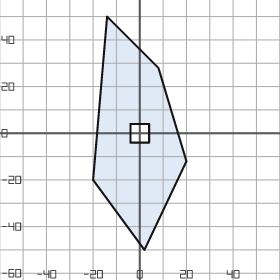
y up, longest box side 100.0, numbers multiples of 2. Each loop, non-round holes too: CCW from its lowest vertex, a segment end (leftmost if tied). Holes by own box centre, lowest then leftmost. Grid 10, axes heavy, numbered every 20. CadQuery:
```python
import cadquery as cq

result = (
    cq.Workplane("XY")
    .moveTo(2.0, -50.0)
    .lineTo(20.0, -12.0)
    .lineTo(8.0, 28.0)
    .lineTo(-14.0, 50.0)
    .lineTo(-20.0, -20.0)
    .close()
    .moveTo(-4.0, -4.0)
    .lineTo(4.0, -4.0)
    .lineTo(4.0, 4.0)
    .lineTo(-4.0, 4.0)
    .close()
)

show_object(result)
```